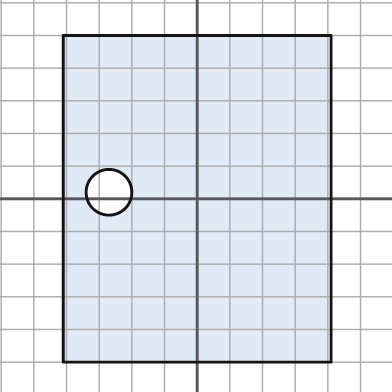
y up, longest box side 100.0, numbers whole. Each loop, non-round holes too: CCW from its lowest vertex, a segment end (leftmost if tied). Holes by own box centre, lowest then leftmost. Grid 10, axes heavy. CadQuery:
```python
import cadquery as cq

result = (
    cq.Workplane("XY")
    .moveTo(-41.0, -50.0)
    .lineTo(41.0, -50.0)
    .lineTo(41.0, 50.0)
    .lineTo(-41.0, 50.0)
    .close()
    .moveTo(-27.0, 2.0)
    .circle(7.0)
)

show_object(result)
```